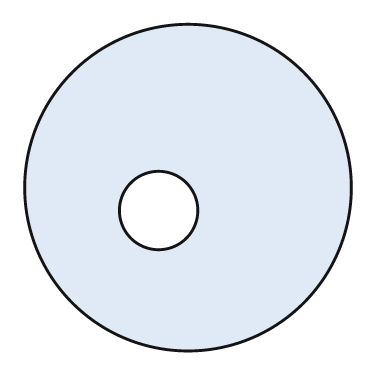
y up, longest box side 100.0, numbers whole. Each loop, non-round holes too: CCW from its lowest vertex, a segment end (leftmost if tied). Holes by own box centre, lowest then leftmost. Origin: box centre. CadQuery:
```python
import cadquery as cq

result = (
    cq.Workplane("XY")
    .moveTo(0.0, 0.0)
    .circle(50.0)
    .moveTo(-9.0, -7.0)
    .circle(12.0)
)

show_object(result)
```